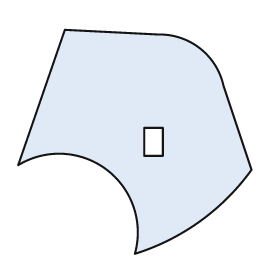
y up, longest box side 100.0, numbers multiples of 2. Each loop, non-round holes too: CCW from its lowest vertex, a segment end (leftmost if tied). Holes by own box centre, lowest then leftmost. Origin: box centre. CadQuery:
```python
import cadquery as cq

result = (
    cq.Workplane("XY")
    .moveTo(0.0, -48.0)
    .threePointArc((28.0, -34.0), (50.0, -12.0))
    .lineTo(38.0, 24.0)
    .threePointArc((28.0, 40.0), (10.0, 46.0))
    .lineTo(-30.0, 48.0)
    .lineTo(-50.0, -10.0)
    .threePointArc((-12.0, -12.0), (0.0, -48.0))
    .close()
    .moveTo(4.0, -6.0)
    .lineTo(12.0, -6.0)
    .lineTo(12.0, 6.0)
    .lineTo(4.0, 6.0)
    .close()
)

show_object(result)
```